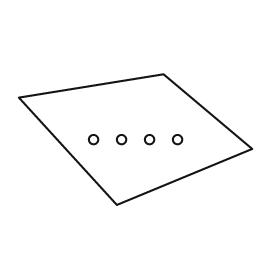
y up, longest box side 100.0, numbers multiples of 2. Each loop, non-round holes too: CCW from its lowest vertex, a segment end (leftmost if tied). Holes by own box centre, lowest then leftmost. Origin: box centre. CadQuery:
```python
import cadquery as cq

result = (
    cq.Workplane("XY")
    .moveTo(-8.0, -28.0)
    .lineTo(50.0, -4.0)
    .lineTo(12.0, 28.0)
    .lineTo(-50.0, 18.0)
    .close()
    .moveTo(-18.0, 0.0)
    .circle(2.0)
    .moveTo(-6.0, 0.0)
    .circle(2.0)
    .moveTo(6.0, 0.0)
    .circle(2.0)
    .moveTo(18.0, 0.0)
    .circle(2.0)
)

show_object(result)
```